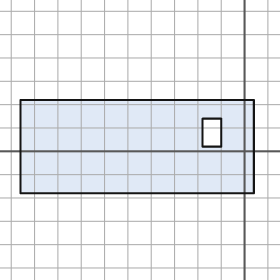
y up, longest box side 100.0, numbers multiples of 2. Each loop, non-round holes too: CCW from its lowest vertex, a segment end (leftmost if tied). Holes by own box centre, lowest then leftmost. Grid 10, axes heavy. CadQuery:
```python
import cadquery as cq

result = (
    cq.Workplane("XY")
    .moveTo(-96.0, -18.0)
    .lineTo(4.0, -18.0)
    .lineTo(4.0, 22.0)
    .lineTo(-96.0, 22.0)
    .close()
    .moveTo(-18.0, 2.0)
    .lineTo(-10.0, 2.0)
    .lineTo(-10.0, 14.0)
    .lineTo(-18.0, 14.0)
    .close()
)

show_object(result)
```